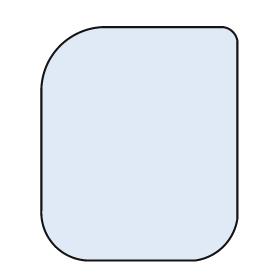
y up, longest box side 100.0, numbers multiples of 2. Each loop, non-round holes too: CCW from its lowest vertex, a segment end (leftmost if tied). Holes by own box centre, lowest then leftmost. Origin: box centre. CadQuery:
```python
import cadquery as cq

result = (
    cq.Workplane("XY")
    .moveTo(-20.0, -50.0)
    .lineTo(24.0, -50.0)
    .threePointArc((36.0, -44.0), (42.0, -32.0))
    .lineTo(42.0, 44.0)
    .threePointArc((40.0, 48.0), (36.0, 50.0))
    .lineTo(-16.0, 50.0)
    .threePointArc((-34.0, 42.0), (-42.0, 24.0))
    .lineTo(-42.0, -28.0)
    .threePointArc((-36.0, -44.0), (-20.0, -50.0))
    .close()
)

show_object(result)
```